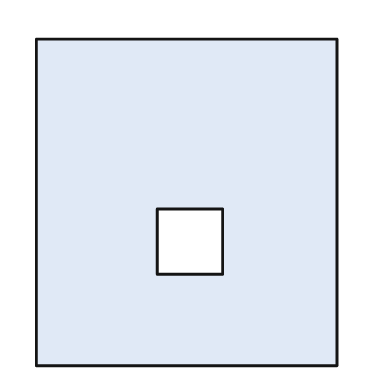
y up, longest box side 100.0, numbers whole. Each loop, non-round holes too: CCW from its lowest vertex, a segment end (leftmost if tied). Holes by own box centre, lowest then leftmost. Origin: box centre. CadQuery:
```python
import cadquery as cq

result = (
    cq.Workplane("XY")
    .moveTo(-46.0, -50.0)
    .lineTo(46.0, -50.0)
    .lineTo(46.0, 50.0)
    .lineTo(-46.0, 50.0)
    .close()
    .moveTo(-9.0, -22.0)
    .lineTo(11.0, -22.0)
    .lineTo(11.0, -2.0)
    .lineTo(-9.0, -2.0)
    .close()
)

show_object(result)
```